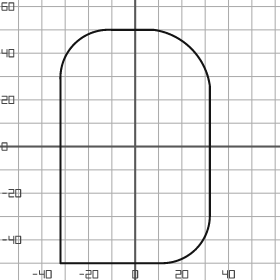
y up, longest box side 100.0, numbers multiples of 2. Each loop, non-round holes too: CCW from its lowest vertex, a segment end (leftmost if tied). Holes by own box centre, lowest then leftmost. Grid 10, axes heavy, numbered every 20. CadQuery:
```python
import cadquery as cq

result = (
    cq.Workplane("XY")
    .moveTo(-32.0, -50.0)
    .lineTo(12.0, -50.0)
    .threePointArc((26.0, -44.0), (32.0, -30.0))
    .lineTo(32.0, 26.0)
    .threePointArc((24.0, 42.0), (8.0, 50.0))
    .lineTo(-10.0, 50.0)
    .threePointArc((-26.0, 44.0), (-32.0, 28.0))
    .close()
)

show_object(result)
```